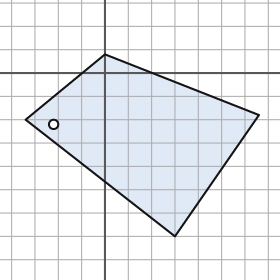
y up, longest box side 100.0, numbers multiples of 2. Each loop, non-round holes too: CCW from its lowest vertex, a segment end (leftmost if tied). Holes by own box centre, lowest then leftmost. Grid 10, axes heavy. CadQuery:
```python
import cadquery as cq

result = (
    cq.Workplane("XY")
    .moveTo(30.0, -70.0)
    .lineTo(66.0, -18.0)
    .lineTo(0.0, 8.0)
    .lineTo(-34.0, -20.0)
    .close()
    .moveTo(-22.0, -22.0)
    .circle(2.0)
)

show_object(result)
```